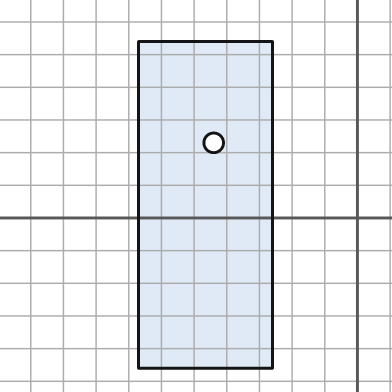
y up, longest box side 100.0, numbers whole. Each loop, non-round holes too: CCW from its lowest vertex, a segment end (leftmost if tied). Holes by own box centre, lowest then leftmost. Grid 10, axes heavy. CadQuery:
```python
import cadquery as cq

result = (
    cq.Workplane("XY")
    .moveTo(-67.0, -46.0)
    .lineTo(-26.0, -46.0)
    .lineTo(-26.0, 54.0)
    .lineTo(-67.0, 54.0)
    .close()
    .moveTo(-44.0, 23.0)
    .circle(3.0)
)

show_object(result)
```